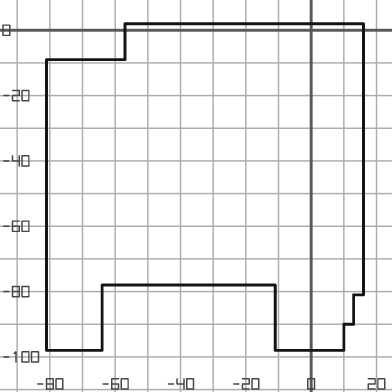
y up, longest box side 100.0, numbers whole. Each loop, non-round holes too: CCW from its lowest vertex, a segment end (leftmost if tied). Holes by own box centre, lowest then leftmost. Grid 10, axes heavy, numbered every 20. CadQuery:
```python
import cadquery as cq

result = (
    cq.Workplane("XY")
    .moveTo(-81.0, -98.0)
    .lineTo(-64.0, -98.0)
    .lineTo(-64.0, -78.0)
    .lineTo(-11.0, -78.0)
    .lineTo(-11.0, -98.0)
    .lineTo(10.0, -98.0)
    .lineTo(10.0, -90.0)
    .lineTo(13.0, -90.0)
    .lineTo(13.0, -81.0)
    .lineTo(16.0, -81.0)
    .lineTo(16.0, 2.0)
    .lineTo(-57.0, 2.0)
    .lineTo(-57.0, -9.0)
    .lineTo(-81.0, -9.0)
    .close()
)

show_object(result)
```